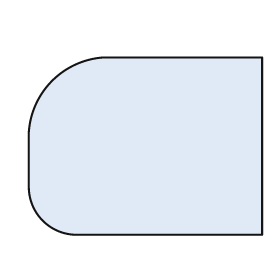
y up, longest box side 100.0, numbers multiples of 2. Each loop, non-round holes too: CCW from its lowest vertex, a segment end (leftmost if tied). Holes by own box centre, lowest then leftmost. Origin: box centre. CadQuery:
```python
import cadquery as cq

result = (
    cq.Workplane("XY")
    .moveTo(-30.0, -38.0)
    .lineTo(50.0, -38.0)
    .lineTo(50.0, 38.0)
    .lineTo(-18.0, 38.0)
    .threePointArc((-40.0, 28.0), (-50.0, 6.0))
    .lineTo(-50.0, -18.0)
    .threePointArc((-44.0, -32.0), (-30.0, -38.0))
    .close()
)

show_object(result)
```